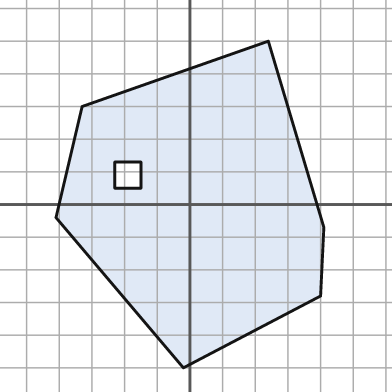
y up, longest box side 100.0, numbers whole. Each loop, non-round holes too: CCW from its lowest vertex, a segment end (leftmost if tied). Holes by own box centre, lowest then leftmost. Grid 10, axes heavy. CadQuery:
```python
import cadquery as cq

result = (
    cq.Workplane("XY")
    .moveTo(-2.0, -50.0)
    .lineTo(40.0, -28.0)
    .lineTo(41.0, -7.0)
    .lineTo(24.0, 50.0)
    .lineTo(-33.0, 30.0)
    .lineTo(-41.0, -4.0)
    .close()
    .moveTo(-23.0, 5.0)
    .lineTo(-15.0, 5.0)
    .lineTo(-15.0, 13.0)
    .lineTo(-23.0, 13.0)
    .close()
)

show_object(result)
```